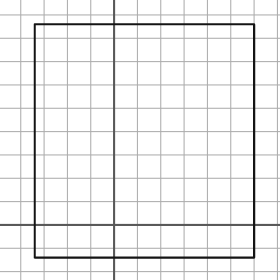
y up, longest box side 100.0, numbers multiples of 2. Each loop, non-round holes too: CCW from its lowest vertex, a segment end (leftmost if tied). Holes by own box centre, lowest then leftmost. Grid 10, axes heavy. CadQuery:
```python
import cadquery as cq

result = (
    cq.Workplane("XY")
    .moveTo(-34.0, -14.0)
    .lineTo(60.0, -14.0)
    .lineTo(60.0, 86.0)
    .lineTo(-34.0, 86.0)
    .close()
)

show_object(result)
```